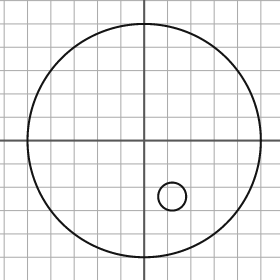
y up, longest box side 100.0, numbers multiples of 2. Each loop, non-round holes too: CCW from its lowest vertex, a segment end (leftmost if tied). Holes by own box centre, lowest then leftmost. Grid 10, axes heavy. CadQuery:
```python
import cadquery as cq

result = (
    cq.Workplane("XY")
    .moveTo(0.0, 0.0)
    .circle(50.0)
    .moveTo(12.0, -24.0)
    .circle(6.0)
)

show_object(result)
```